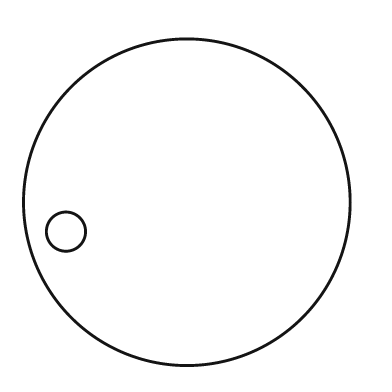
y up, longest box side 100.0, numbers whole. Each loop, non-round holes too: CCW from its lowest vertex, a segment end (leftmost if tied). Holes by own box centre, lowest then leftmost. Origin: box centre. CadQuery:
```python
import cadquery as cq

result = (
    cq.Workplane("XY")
    .moveTo(0.0, 0.0)
    .circle(50.0)
    .moveTo(-37.0, -9.0)
    .circle(6.0)
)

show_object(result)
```